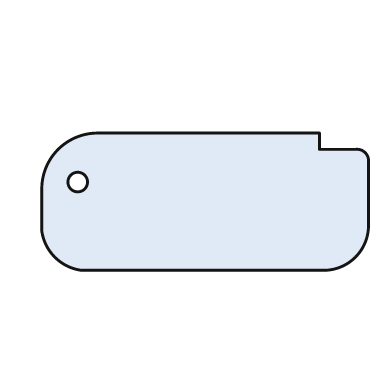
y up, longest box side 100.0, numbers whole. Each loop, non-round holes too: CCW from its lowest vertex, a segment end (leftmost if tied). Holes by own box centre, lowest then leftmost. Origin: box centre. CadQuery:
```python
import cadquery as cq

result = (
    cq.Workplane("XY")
    .moveTo(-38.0, -21.0)
    .lineTo(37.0, -21.0)
    .threePointArc((46.0, -17.0), (50.0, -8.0))
    .lineTo(50.0, 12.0)
    .threePointArc((49.0, 15.0), (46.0, 16.0))
    .lineTo(35.0, 16.0)
    .lineTo(35.0, 21.0)
    .lineTo(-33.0, 21.0)
    .threePointArc((-45.0, 16.0), (-50.0, 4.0))
    .lineTo(-50.0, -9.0)
    .threePointArc((-46.0, -17.0), (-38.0, -21.0))
    .close()
    .moveTo(-39.0, 6.0)
    .circle(3.0)
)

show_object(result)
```